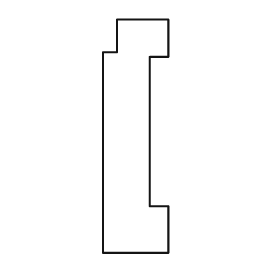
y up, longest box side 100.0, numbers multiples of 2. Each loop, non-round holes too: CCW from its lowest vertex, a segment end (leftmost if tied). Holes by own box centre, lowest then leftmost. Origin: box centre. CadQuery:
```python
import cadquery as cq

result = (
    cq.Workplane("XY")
    .moveTo(-14.0, -50.0)
    .lineTo(14.0, -50.0)
    .lineTo(14.0, -30.0)
    .lineTo(6.0, -30.0)
    .lineTo(6.0, 34.0)
    .lineTo(14.0, 34.0)
    .lineTo(14.0, 50.0)
    .lineTo(-8.0, 50.0)
    .lineTo(-8.0, 36.0)
    .lineTo(-14.0, 36.0)
    .close()
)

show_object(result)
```